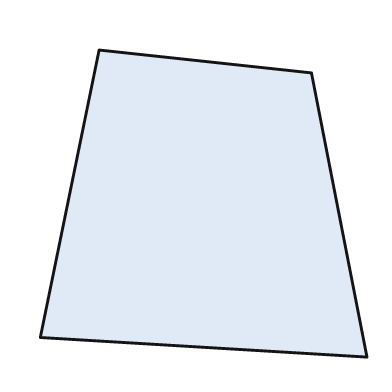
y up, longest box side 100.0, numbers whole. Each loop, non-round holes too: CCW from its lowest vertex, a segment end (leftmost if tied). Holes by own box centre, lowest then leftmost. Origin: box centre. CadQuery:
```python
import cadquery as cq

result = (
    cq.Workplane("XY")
    .moveTo(50.0, -47.0)
    .lineTo(33.0, 40.0)
    .lineTo(-32.0, 47.0)
    .lineTo(-50.0, -41.0)
    .close()
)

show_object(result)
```